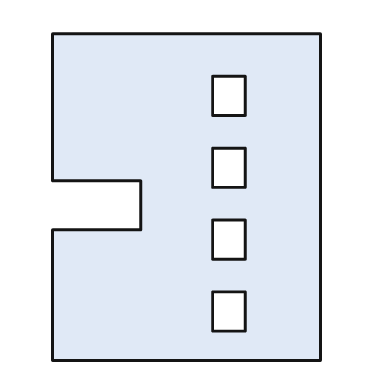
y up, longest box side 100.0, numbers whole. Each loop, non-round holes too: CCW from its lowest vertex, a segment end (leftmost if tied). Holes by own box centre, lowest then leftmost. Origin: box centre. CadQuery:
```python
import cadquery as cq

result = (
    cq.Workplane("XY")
    .moveTo(-41.0, -50.0)
    .lineTo(41.0, -50.0)
    .lineTo(41.0, 50.0)
    .lineTo(-41.0, 50.0)
    .lineTo(-41.0, 5.0)
    .lineTo(-14.0, 5.0)
    .lineTo(-14.0, -10.0)
    .lineTo(-41.0, -10.0)
    .close()
    .moveTo(8.0, -41.0)
    .lineTo(18.0, -41.0)
    .lineTo(18.0, -29.0)
    .lineTo(8.0, -29.0)
    .close()
    .moveTo(8.0, -19.0)
    .lineTo(18.0, -19.0)
    .lineTo(18.0, -7.0)
    .lineTo(8.0, -7.0)
    .close()
    .moveTo(8.0, 3.0)
    .lineTo(18.0, 3.0)
    .lineTo(18.0, 15.0)
    .lineTo(8.0, 15.0)
    .close()
    .moveTo(8.0, 25.0)
    .lineTo(18.0, 25.0)
    .lineTo(18.0, 37.0)
    .lineTo(8.0, 37.0)
    .close()
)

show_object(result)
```